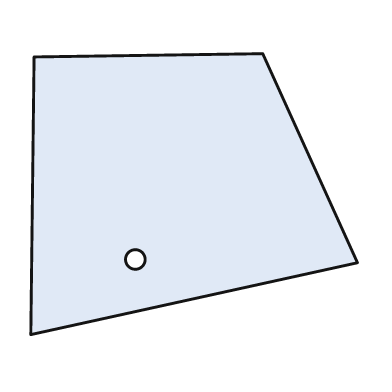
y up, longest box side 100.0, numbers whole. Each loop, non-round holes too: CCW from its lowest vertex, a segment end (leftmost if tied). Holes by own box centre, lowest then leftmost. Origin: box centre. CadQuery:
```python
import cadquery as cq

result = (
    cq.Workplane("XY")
    .moveTo(-50.0, -43.0)
    .lineTo(50.0, -21.0)
    .lineTo(21.0, 43.0)
    .lineTo(-49.0, 42.0)
    .close()
    .moveTo(-18.0, -20.0)
    .circle(3.0)
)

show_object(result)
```